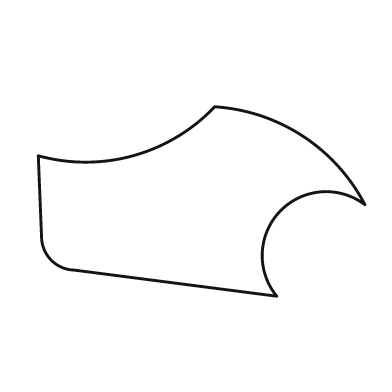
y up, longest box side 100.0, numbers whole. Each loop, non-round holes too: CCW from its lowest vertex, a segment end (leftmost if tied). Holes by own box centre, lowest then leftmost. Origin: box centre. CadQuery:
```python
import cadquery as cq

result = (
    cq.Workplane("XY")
    .moveTo(23.0, -29.0)
    .threePointArc((24.0, -3.0), (50.0, -1.0))
    .threePointArc((31.0, 20.0), (4.0, 29.0))
    .threePointArc((-21.0, 14.0), (-50.0, 14.0))
    .lineTo(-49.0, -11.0)
    .threePointArc((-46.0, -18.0), (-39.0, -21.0))
    .close()
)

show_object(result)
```